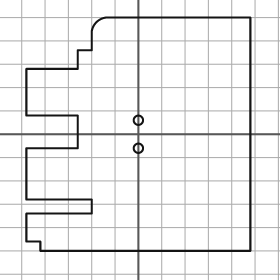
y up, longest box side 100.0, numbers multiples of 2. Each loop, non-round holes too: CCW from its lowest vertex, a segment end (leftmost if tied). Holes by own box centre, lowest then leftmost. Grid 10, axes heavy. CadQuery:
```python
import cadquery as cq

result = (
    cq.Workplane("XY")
    .moveTo(-42.0, -50.0)
    .lineTo(48.0, -50.0)
    .lineTo(48.0, 50.0)
    .lineTo(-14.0, 50.0)
    .threePointArc((-18.0, 48.0), (-20.0, 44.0))
    .lineTo(-20.0, 36.0)
    .lineTo(-26.0, 36.0)
    .lineTo(-26.0, 28.0)
    .lineTo(-48.0, 28.0)
    .lineTo(-48.0, 8.0)
    .lineTo(-26.0, 8.0)
    .lineTo(-26.0, -6.0)
    .lineTo(-48.0, -6.0)
    .lineTo(-48.0, -28.0)
    .lineTo(-20.0, -28.0)
    .lineTo(-20.0, -34.0)
    .lineTo(-48.0, -34.0)
    .lineTo(-48.0, -46.0)
    .lineTo(-42.0, -46.0)
    .close()
    .moveTo(0.0, -6.0)
    .circle(2.0)
    .moveTo(0.0, 6.0)
    .circle(2.0)
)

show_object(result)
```